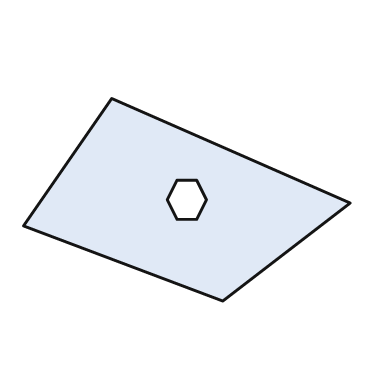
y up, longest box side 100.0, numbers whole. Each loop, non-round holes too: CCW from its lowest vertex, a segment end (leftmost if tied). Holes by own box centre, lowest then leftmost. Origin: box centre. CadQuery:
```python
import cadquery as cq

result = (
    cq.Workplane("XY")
    .moveTo(11.0, -31.0)
    .lineTo(50.0, -1.0)
    .lineTo(-23.0, 31.0)
    .lineTo(-50.0, -8.0)
    .close()
    .moveTo(-3.0, -6.0)
    .lineTo(3.0, -6.0)
    .lineTo(6.0, 0.0)
    .lineTo(3.0, 6.0)
    .lineTo(-3.0, 6.0)
    .lineTo(-6.0, 0.0)
    .close()
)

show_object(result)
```